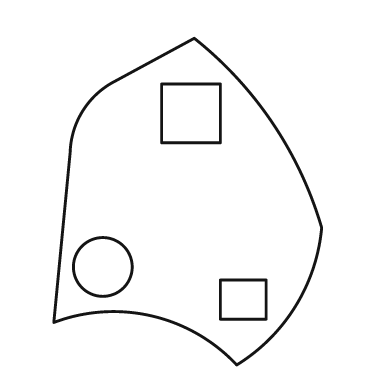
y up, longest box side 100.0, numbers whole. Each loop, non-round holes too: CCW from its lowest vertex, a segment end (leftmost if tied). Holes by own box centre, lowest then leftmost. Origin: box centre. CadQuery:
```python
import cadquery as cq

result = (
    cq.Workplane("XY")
    .moveTo(15.0, -50.0)
    .threePointArc((33.0, -32.0), (41.0, -8.0))
    .threePointArc((26.0, 24.0), (2.0, 50.0))
    .lineTo(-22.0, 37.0)
    .threePointArc((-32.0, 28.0), (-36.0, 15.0))
    .lineTo(-41.0, -37.0)
    .threePointArc((-11.0, -35.0), (15.0, -50.0))
    .close()
    .moveTo(10.0, -36.0)
    .lineTo(24.0, -36.0)
    .lineTo(24.0, -24.0)
    .lineTo(10.0, -24.0)
    .close()
    .moveTo(-26.0, -20.0)
    .circle(9.0)
    .moveTo(-8.0, 18.0)
    .lineTo(10.0, 18.0)
    .lineTo(10.0, 36.0)
    .lineTo(-8.0, 36.0)
    .close()
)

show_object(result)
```